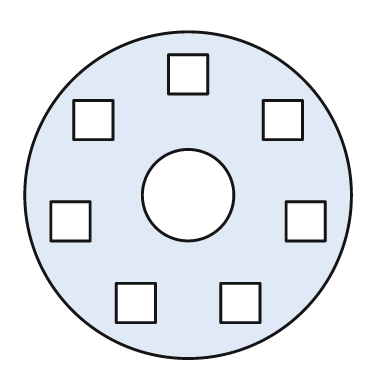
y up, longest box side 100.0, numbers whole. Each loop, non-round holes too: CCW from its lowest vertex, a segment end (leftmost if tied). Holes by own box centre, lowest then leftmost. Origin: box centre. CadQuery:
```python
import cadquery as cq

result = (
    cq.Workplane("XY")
    .moveTo(0.0, 0.0)
    .circle(50.0)
    .moveTo(-22.0, -39.0)
    .lineTo(-10.0, -39.0)
    .lineTo(-10.0, -27.0)
    .lineTo(-22.0, -27.0)
    .close()
    .moveTo(10.0, -39.0)
    .lineTo(22.0, -39.0)
    .lineTo(22.0, -27.0)
    .lineTo(10.0, -27.0)
    .close()
    .moveTo(-42.0, -14.0)
    .lineTo(-30.0, -14.0)
    .lineTo(-30.0, -2.0)
    .lineTo(-42.0, -2.0)
    .close()
    .moveTo(30.0, -14.0)
    .lineTo(42.0, -14.0)
    .lineTo(42.0, -2.0)
    .lineTo(30.0, -2.0)
    .close()
    .moveTo(0.0, 0.0)
    .circle(14.0)
    .moveTo(-35.0, 17.0)
    .lineTo(-23.0, 17.0)
    .lineTo(-23.0, 29.0)
    .lineTo(-35.0, 29.0)
    .close()
    .moveTo(23.0, 17.0)
    .lineTo(35.0, 17.0)
    .lineTo(35.0, 29.0)
    .lineTo(23.0, 29.0)
    .close()
    .moveTo(-6.0, 31.0)
    .lineTo(6.0, 31.0)
    .lineTo(6.0, 43.0)
    .lineTo(-6.0, 43.0)
    .close()
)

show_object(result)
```